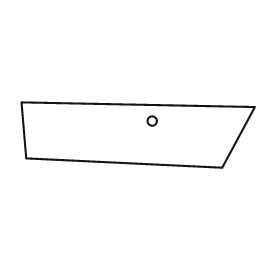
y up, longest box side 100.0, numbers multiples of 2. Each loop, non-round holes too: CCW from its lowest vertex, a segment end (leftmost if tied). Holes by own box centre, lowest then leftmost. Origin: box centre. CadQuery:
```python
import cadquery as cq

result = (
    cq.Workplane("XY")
    .moveTo(36.0, -14.0)
    .lineTo(50.0, 12.0)
    .lineTo(-50.0, 14.0)
    .lineTo(-48.0, -10.0)
    .close()
    .moveTo(6.0, 6.0)
    .circle(2.0)
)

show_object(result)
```